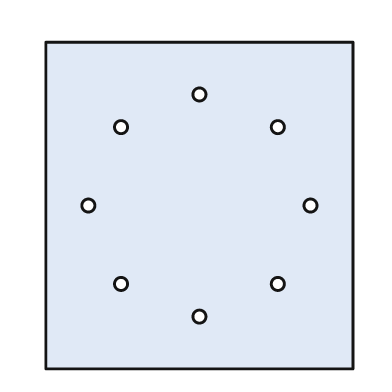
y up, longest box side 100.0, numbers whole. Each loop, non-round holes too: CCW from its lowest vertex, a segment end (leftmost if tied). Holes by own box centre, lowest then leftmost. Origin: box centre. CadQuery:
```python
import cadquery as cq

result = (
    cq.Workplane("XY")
    .moveTo(-47.0, -50.0)
    .lineTo(47.0, -50.0)
    .lineTo(47.0, 50.0)
    .lineTo(-47.0, 50.0)
    .close()
    .moveTo(0.0, -34.0)
    .circle(2.0)
    .moveTo(-24.0, -24.0)
    .circle(2.0)
    .moveTo(24.0, -24.0)
    .circle(2.0)
    .moveTo(-34.0, 0.0)
    .circle(2.0)
    .moveTo(34.0, 0.0)
    .circle(2.0)
    .moveTo(-24.0, 24.0)
    .circle(2.0)
    .moveTo(24.0, 24.0)
    .circle(2.0)
    .moveTo(0.0, 34.0)
    .circle(2.0)
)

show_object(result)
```